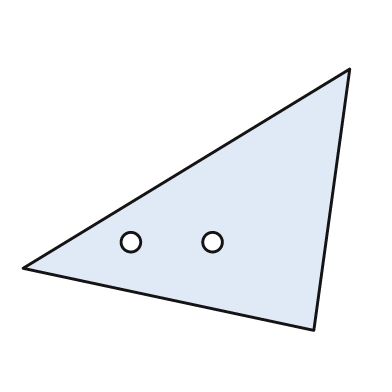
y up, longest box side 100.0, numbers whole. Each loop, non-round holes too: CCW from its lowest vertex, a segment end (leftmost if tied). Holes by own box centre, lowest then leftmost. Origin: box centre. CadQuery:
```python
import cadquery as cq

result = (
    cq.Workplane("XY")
    .moveTo(39.0, -40.0)
    .lineTo(50.0, 40.0)
    .lineTo(-50.0, -21.0)
    .close()
    .moveTo(-17.0, -13.0)
    .circle(3.0)
    .moveTo(8.0, -13.0)
    .circle(3.0)
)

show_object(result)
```